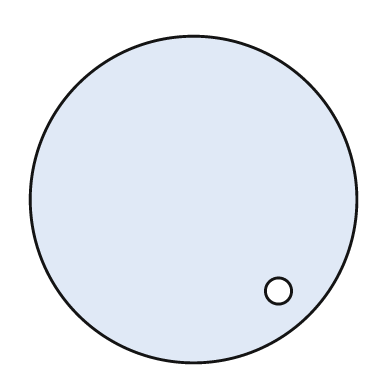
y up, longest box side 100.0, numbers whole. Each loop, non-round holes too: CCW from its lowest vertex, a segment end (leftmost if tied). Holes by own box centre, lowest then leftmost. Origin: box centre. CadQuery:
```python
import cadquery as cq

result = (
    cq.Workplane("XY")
    .moveTo(0.0, 0.0)
    .circle(50.0)
    .moveTo(26.0, -28.0)
    .circle(4.0)
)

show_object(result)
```